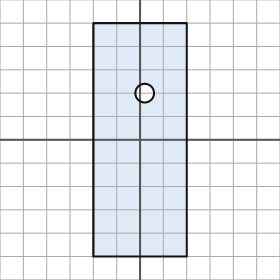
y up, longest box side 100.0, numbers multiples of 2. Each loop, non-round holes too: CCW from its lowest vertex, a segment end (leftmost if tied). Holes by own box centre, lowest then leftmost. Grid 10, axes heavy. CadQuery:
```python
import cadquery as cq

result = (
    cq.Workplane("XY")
    .moveTo(-20.0, -50.0)
    .lineTo(20.0, -50.0)
    .lineTo(20.0, 50.0)
    .lineTo(-20.0, 50.0)
    .close()
    .moveTo(2.0, 20.0)
    .circle(4.0)
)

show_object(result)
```